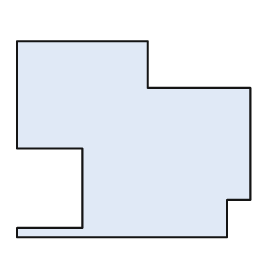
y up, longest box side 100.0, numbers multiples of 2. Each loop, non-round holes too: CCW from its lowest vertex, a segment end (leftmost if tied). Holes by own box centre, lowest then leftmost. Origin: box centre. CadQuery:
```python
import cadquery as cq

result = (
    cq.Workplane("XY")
    .moveTo(-50.0, -42.0)
    .lineTo(40.0, -42.0)
    .lineTo(40.0, -26.0)
    .lineTo(50.0, -26.0)
    .lineTo(50.0, 22.0)
    .lineTo(6.0, 22.0)
    .lineTo(6.0, 42.0)
    .lineTo(-50.0, 42.0)
    .lineTo(-50.0, -4.0)
    .lineTo(-22.0, -4.0)
    .lineTo(-22.0, -38.0)
    .lineTo(-50.0, -38.0)
    .close()
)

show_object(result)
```